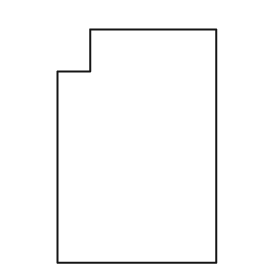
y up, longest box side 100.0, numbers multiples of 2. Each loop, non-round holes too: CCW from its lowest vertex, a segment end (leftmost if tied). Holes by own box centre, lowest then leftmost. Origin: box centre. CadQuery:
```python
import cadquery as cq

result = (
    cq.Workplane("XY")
    .moveTo(-34.0, -50.0)
    .lineTo(34.0, -50.0)
    .lineTo(34.0, 50.0)
    .lineTo(-20.0, 50.0)
    .lineTo(-20.0, 32.0)
    .lineTo(-34.0, 32.0)
    .close()
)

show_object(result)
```